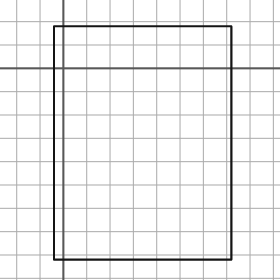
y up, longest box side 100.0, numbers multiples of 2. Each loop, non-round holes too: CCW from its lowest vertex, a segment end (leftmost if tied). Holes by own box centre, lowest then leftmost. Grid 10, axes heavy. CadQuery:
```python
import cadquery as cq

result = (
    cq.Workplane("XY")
    .moveTo(-4.0, -82.0)
    .lineTo(72.0, -82.0)
    .lineTo(72.0, 18.0)
    .lineTo(-4.0, 18.0)
    .close()
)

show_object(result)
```